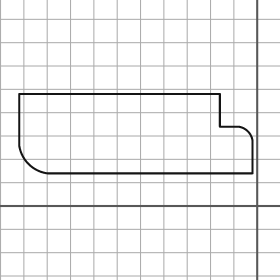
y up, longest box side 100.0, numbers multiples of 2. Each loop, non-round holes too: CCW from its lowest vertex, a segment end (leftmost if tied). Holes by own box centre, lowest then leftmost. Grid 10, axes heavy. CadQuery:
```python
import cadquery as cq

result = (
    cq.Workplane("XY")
    .moveTo(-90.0, 14.0)
    .lineTo(-2.0, 14.0)
    .lineTo(-2.0, 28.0)
    .threePointArc((-4.0, 32.0), (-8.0, 34.0))
    .lineTo(-16.0, 34.0)
    .lineTo(-16.0, 48.0)
    .lineTo(-102.0, 48.0)
    .lineTo(-102.0, 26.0)
    .threePointArc((-98.0, 18.0), (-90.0, 14.0))
    .close()
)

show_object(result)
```